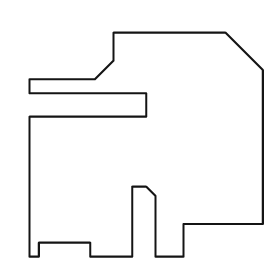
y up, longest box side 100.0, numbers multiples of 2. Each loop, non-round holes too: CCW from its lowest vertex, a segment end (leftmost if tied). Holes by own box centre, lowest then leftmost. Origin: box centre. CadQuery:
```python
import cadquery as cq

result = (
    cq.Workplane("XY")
    .moveTo(-50.0, -48.0)
    .lineTo(-46.0, -48.0)
    .lineTo(-46.0, -42.0)
    .lineTo(-24.0, -42.0)
    .lineTo(-24.0, -48.0)
    .lineTo(-6.0, -48.0)
    .lineTo(-6.0, -18.0)
    .lineTo(0.0, -18.0)
    .lineTo(4.0, -22.0)
    .lineTo(4.0, -48.0)
    .lineTo(16.0, -48.0)
    .lineTo(16.0, -34.0)
    .lineTo(50.0, -34.0)
    .lineTo(50.0, 32.0)
    .lineTo(34.0, 48.0)
    .lineTo(-14.0, 48.0)
    .lineTo(-14.0, 36.0)
    .lineTo(-22.0, 28.0)
    .lineTo(-50.0, 28.0)
    .lineTo(-50.0, 22.0)
    .lineTo(0.0, 22.0)
    .lineTo(0.0, 12.0)
    .lineTo(-50.0, 12.0)
    .close()
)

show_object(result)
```